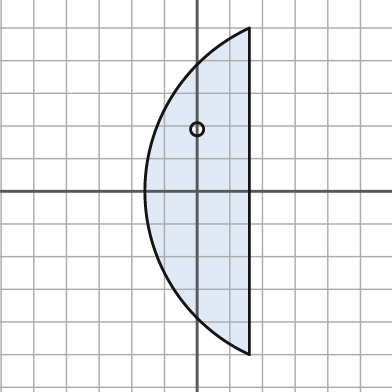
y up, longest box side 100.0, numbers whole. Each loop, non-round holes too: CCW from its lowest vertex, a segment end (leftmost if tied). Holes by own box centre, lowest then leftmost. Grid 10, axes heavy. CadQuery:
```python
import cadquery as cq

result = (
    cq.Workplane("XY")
    .moveTo(16.0, -50.0)
    .lineTo(16.0, 50.0)
    .threePointArc((-16.0, 0.0), (16.0, -50.0))
    .close()
    .moveTo(0.0, 19.0)
    .circle(2.0)
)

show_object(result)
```